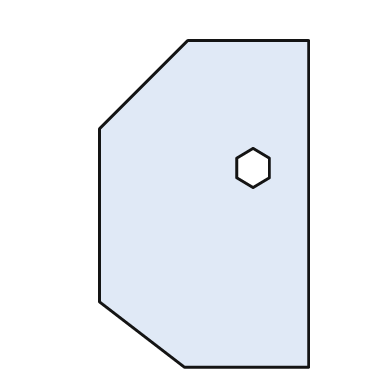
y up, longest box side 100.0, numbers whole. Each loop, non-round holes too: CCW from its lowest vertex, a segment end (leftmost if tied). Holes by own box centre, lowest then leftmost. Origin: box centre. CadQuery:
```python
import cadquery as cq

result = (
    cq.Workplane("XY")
    .moveTo(-6.0, -50.0)
    .lineTo(32.0, -50.0)
    .lineTo(32.0, 50.0)
    .lineTo(-5.0, 50.0)
    .lineTo(-32.0, 23.0)
    .lineTo(-32.0, -30.0)
    .close()
    .moveTo(15.0, 5.0)
    .lineTo(20.0, 8.0)
    .lineTo(20.0, 14.0)
    .lineTo(15.0, 17.0)
    .lineTo(10.0, 14.0)
    .lineTo(10.0, 8.0)
    .close()
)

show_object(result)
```